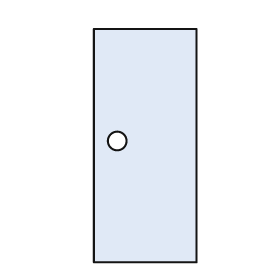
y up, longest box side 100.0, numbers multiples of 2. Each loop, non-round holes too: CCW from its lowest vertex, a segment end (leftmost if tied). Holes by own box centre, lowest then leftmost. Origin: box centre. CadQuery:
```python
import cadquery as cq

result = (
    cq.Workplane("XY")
    .moveTo(-22.0, -50.0)
    .lineTo(22.0, -50.0)
    .lineTo(22.0, 50.0)
    .lineTo(-22.0, 50.0)
    .close()
    .moveTo(-12.0, 2.0)
    .circle(4.0)
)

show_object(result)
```